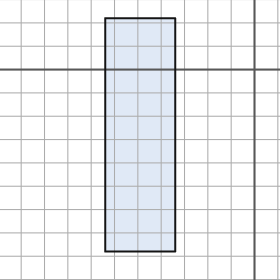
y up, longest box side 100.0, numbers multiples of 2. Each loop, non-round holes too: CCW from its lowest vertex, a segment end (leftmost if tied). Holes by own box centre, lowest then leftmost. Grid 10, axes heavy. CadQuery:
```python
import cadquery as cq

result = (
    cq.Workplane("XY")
    .moveTo(-64.0, -78.0)
    .lineTo(-34.0, -78.0)
    .lineTo(-34.0, 22.0)
    .lineTo(-64.0, 22.0)
    .close()
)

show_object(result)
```